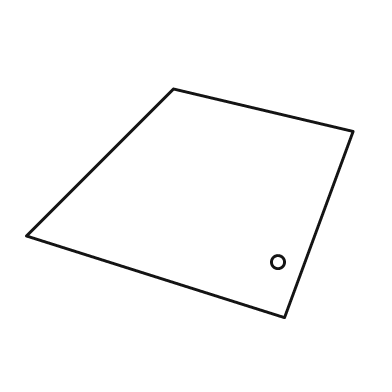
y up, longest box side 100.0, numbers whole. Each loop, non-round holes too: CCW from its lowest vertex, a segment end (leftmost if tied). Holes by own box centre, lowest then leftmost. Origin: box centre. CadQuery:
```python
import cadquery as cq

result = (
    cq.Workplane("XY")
    .moveTo(29.0, -35.0)
    .lineTo(50.0, 22.0)
    .lineTo(-5.0, 35.0)
    .lineTo(-50.0, -10.0)
    .close()
    .moveTo(27.0, -18.0)
    .circle(2.0)
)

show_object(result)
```